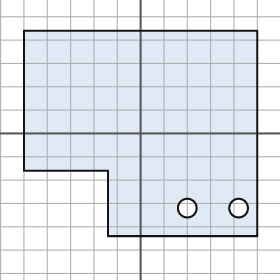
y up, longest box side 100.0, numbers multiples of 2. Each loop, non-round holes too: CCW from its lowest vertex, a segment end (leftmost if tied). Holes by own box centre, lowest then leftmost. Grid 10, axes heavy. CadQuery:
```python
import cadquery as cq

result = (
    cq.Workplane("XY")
    .moveTo(-14.0, -44.0)
    .lineTo(50.0, -44.0)
    .lineTo(50.0, 44.0)
    .lineTo(-50.0, 44.0)
    .lineTo(-50.0, -16.0)
    .lineTo(-14.0, -16.0)
    .close()
    .moveTo(20.0, -32.0)
    .circle(4.0)
    .moveTo(42.0, -32.0)
    .circle(4.0)
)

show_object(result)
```